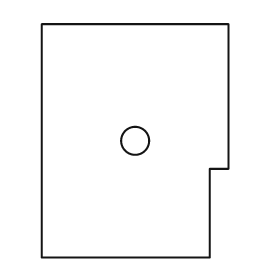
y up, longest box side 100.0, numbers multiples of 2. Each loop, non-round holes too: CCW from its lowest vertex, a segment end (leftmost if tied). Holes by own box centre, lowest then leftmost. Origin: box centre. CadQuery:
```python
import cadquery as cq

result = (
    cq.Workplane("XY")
    .moveTo(-40.0, -50.0)
    .lineTo(32.0, -50.0)
    .lineTo(32.0, -12.0)
    .lineTo(40.0, -12.0)
    .lineTo(40.0, 50.0)
    .lineTo(-40.0, 50.0)
    .close()
    .moveTo(0.0, 0.0)
    .circle(6.0)
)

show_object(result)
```